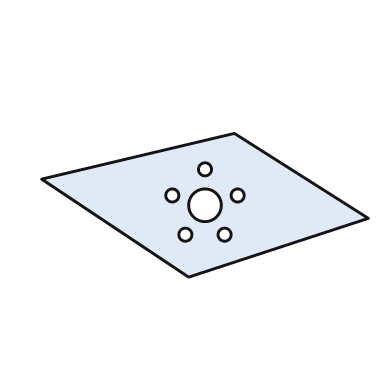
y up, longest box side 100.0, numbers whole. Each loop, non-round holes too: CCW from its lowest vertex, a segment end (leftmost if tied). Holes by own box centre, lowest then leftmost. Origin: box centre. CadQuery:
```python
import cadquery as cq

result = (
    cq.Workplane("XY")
    .moveTo(-5.0, -22.0)
    .lineTo(50.0, -4.0)
    .lineTo(9.0, 22.0)
    .lineTo(-50.0, 8.0)
    .close()
    .moveTo(-6.0, -9.0)
    .circle(2.0)
    .moveTo(6.0, -9.0)
    .circle(2.0)
    .moveTo(0.0, 0.0)
    .circle(5.0)
    .moveTo(-10.0, 3.0)
    .circle(2.0)
    .moveTo(10.0, 3.0)
    .circle(2.0)
    .moveTo(0.0, 11.0)
    .circle(2.0)
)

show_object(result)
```